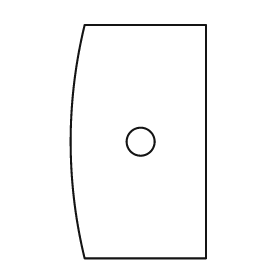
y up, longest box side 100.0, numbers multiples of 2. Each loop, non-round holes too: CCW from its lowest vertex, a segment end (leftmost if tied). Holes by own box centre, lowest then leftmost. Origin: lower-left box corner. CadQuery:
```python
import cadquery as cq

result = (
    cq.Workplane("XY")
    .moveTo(6.0, 0.0)
    .lineTo(58.0, 0.0)
    .lineTo(58.0, 100.0)
    .lineTo(6.0, 100.0)
    .threePointArc((0.0, 50.0), (6.0, 0.0))
    .close()
    .moveTo(30.0, 50.0)
    .circle(6.0)
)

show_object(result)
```